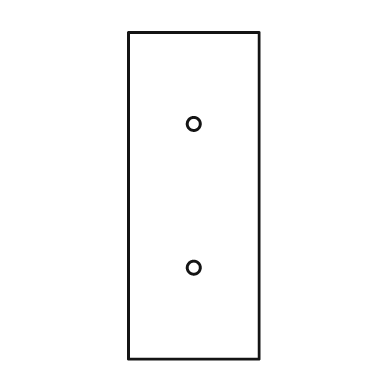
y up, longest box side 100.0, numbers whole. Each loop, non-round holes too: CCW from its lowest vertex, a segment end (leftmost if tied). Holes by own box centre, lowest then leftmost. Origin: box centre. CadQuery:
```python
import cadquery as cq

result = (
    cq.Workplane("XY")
    .moveTo(-20.0, -50.0)
    .lineTo(20.0, -50.0)
    .lineTo(20.0, 50.0)
    .lineTo(-20.0, 50.0)
    .close()
    .moveTo(0.0, -22.0)
    .circle(2.0)
    .moveTo(0.0, 22.0)
    .circle(2.0)
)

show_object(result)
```